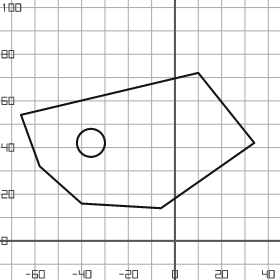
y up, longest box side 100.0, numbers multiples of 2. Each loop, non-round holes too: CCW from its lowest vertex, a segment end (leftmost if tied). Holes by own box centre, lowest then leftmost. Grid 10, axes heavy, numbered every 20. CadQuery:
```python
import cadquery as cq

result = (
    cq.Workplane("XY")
    .moveTo(-6.0, 14.0)
    .lineTo(34.0, 42.0)
    .lineTo(10.0, 72.0)
    .lineTo(-66.0, 54.0)
    .lineTo(-58.0, 32.0)
    .lineTo(-40.0, 16.0)
    .close()
    .moveTo(-36.0, 42.0)
    .circle(6.0)
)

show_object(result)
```